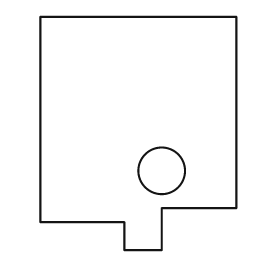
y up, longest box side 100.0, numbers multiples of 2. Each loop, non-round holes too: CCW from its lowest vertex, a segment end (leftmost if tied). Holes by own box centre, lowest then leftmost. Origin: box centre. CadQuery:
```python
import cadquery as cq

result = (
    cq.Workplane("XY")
    .moveTo(-6.0, -50.0)
    .lineTo(10.0, -50.0)
    .lineTo(10.0, -32.0)
    .lineTo(42.0, -32.0)
    .lineTo(42.0, 50.0)
    .lineTo(-42.0, 50.0)
    .lineTo(-42.0, -38.0)
    .lineTo(-6.0, -38.0)
    .close()
    .moveTo(10.0, -16.0)
    .circle(10.0)
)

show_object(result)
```